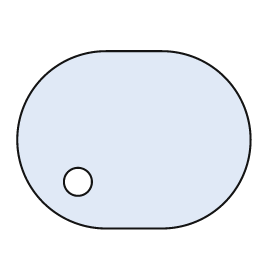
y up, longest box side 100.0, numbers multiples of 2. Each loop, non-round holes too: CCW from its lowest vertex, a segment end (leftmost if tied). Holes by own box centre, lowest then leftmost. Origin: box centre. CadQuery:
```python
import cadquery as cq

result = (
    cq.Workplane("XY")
    .moveTo(-12.0, -38.0)
    .lineTo(12.0, -38.0)
    .threePointArc((50.0, 0.0), (12.0, 38.0))
    .lineTo(-12.0, 38.0)
    .threePointArc((-50.0, 0.0), (-12.0, -38.0))
    .close()
    .moveTo(-24.0, -18.0)
    .circle(6.0)
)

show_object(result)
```